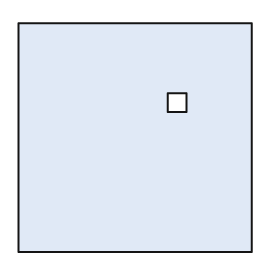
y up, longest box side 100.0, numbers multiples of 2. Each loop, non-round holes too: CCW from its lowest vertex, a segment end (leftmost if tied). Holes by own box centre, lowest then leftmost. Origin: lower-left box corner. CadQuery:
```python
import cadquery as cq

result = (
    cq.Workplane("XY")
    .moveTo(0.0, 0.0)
    .lineTo(100.0, 0.0)
    .lineTo(100.0, 98.0)
    .lineTo(0.0, 98.0)
    .close()
    .moveTo(64.0, 60.0)
    .lineTo(72.0, 60.0)
    .lineTo(72.0, 68.0)
    .lineTo(64.0, 68.0)
    .close()
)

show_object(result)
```